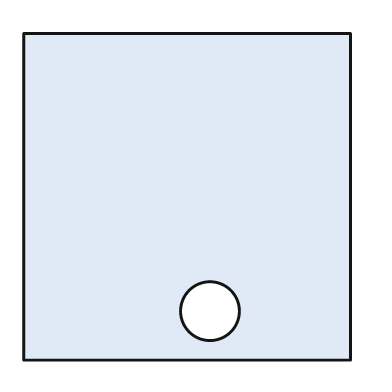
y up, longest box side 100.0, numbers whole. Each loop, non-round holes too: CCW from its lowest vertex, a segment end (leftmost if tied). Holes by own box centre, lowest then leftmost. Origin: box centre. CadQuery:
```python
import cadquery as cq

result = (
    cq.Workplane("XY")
    .moveTo(-50.0, -50.0)
    .lineTo(50.0, -50.0)
    .lineTo(50.0, 50.0)
    .lineTo(-50.0, 50.0)
    .close()
    .moveTo(7.0, -35.0)
    .circle(9.0)
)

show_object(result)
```